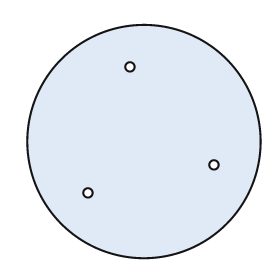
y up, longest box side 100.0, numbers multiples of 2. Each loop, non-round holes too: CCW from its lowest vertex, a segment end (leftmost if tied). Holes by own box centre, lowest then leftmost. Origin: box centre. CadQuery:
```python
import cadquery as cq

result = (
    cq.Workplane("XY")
    .moveTo(0.0, 0.0)
    .circle(50.0)
    .moveTo(-24.0, -22.0)
    .circle(2.0)
    .moveTo(30.0, -10.0)
    .circle(2.0)
    .moveTo(-6.0, 32.0)
    .circle(2.0)
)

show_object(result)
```